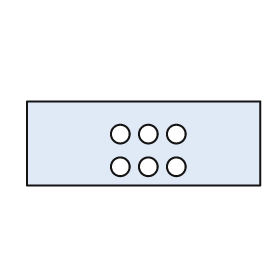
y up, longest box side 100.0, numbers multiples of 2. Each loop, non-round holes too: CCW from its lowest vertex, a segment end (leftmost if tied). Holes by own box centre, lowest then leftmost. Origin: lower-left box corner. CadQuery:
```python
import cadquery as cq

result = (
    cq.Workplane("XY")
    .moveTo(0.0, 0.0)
    .lineTo(100.0, 0.0)
    .lineTo(100.0, 36.0)
    .lineTo(0.0, 36.0)
    .close()
    .moveTo(40.0, 8.0)
    .circle(4.0)
    .moveTo(52.0, 8.0)
    .circle(4.0)
    .moveTo(64.0, 8.0)
    .circle(4.0)
    .moveTo(40.0, 22.0)
    .circle(4.0)
    .moveTo(52.0, 22.0)
    .circle(4.0)
    .moveTo(64.0, 22.0)
    .circle(4.0)
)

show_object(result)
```